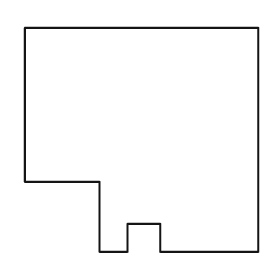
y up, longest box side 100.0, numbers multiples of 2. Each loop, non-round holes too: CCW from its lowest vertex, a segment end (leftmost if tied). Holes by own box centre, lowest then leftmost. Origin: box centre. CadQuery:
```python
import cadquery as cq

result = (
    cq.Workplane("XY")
    .moveTo(-18.0, -48.0)
    .lineTo(-6.0, -48.0)
    .lineTo(-6.0, -36.0)
    .lineTo(8.0, -36.0)
    .lineTo(8.0, -48.0)
    .lineTo(50.0, -48.0)
    .lineTo(50.0, 48.0)
    .lineTo(-50.0, 48.0)
    .lineTo(-50.0, -18.0)
    .lineTo(-18.0, -18.0)
    .close()
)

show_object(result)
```